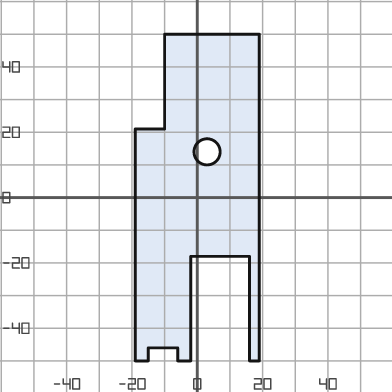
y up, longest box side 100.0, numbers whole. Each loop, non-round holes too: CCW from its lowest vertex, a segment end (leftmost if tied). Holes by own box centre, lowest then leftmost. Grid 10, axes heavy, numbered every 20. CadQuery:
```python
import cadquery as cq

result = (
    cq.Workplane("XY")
    .moveTo(-19.0, -50.0)
    .lineTo(-15.0, -50.0)
    .lineTo(-15.0, -46.0)
    .lineTo(-6.0, -46.0)
    .lineTo(-6.0, -50.0)
    .lineTo(-2.0, -50.0)
    .lineTo(-2.0, -18.0)
    .lineTo(16.0, -18.0)
    .lineTo(16.0, -50.0)
    .lineTo(19.0, -50.0)
    .lineTo(19.0, 50.0)
    .lineTo(-10.0, 50.0)
    .lineTo(-10.0, 21.0)
    .lineTo(-19.0, 21.0)
    .close()
    .moveTo(3.0, 14.0)
    .circle(4.0)
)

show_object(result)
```